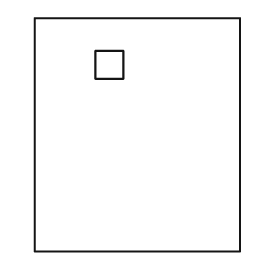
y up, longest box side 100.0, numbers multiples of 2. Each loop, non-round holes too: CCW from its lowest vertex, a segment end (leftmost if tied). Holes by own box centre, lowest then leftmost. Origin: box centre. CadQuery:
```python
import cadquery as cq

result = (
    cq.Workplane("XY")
    .moveTo(-44.0, -50.0)
    .lineTo(44.0, -50.0)
    .lineTo(44.0, 50.0)
    .lineTo(-44.0, 50.0)
    .close()
    .moveTo(-18.0, 24.0)
    .lineTo(-6.0, 24.0)
    .lineTo(-6.0, 36.0)
    .lineTo(-18.0, 36.0)
    .close()
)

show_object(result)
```